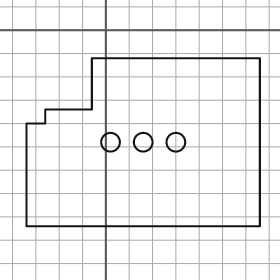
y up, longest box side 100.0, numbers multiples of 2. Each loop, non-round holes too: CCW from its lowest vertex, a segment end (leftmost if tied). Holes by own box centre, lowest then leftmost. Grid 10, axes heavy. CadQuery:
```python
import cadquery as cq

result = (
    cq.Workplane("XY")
    .moveTo(-34.0, -84.0)
    .lineTo(66.0, -84.0)
    .lineTo(66.0, -12.0)
    .lineTo(-6.0, -12.0)
    .lineTo(-6.0, -34.0)
    .lineTo(-26.0, -34.0)
    .lineTo(-26.0, -40.0)
    .lineTo(-34.0, -40.0)
    .close()
    .moveTo(2.0, -48.0)
    .circle(4.0)
    .moveTo(16.0, -48.0)
    .circle(4.0)
    .moveTo(30.0, -48.0)
    .circle(4.0)
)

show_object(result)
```